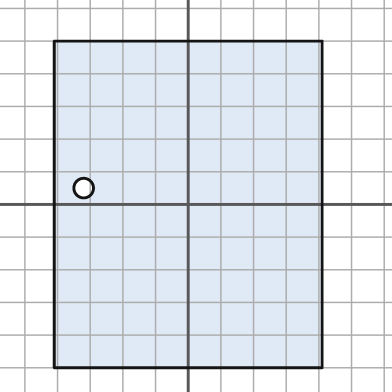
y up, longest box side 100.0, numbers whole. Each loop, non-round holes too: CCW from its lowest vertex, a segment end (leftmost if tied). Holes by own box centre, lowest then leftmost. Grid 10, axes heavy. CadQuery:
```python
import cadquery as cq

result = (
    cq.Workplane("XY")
    .moveTo(-41.0, -50.0)
    .lineTo(41.0, -50.0)
    .lineTo(41.0, 50.0)
    .lineTo(-41.0, 50.0)
    .close()
    .moveTo(-32.0, 5.0)
    .circle(3.0)
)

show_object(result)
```